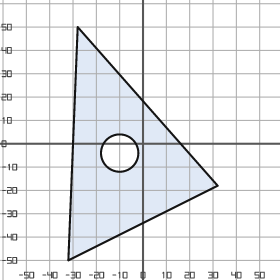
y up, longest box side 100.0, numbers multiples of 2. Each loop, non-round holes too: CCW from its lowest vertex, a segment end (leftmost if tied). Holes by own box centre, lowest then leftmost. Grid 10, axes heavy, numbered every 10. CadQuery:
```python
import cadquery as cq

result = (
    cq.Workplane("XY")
    .moveTo(-32.0, -50.0)
    .lineTo(32.0, -18.0)
    .lineTo(-28.0, 50.0)
    .close()
    .moveTo(-10.0, -4.0)
    .circle(8.0)
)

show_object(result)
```